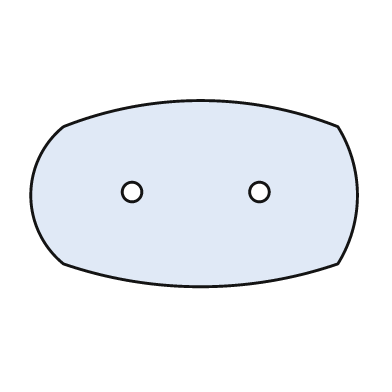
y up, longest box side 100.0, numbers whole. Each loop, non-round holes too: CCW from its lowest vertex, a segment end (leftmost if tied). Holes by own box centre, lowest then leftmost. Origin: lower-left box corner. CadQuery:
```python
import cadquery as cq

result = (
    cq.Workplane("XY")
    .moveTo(10.0, 7.0)
    .threePointArc((52.0, 0.0), (94.0, 7.0))
    .threePointArc((100.0, 28.0), (94.0, 49.0))
    .threePointArc((52.0, 57.0), (10.0, 49.0))
    .threePointArc((0.0, 28.0), (10.0, 7.0))
    .close()
    .moveTo(31.0, 29.0)
    .circle(3.0)
    .moveTo(70.0, 29.0)
    .circle(3.0)
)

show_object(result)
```